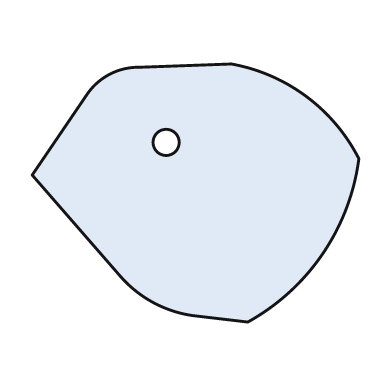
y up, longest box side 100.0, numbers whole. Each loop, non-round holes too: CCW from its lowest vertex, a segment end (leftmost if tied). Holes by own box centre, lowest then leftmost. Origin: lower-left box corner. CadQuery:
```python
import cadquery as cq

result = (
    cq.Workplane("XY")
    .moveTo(66.0, 0.0)
    .threePointArc((89.0, 21.0), (100.0, 50.0))
    .threePointArc((84.0, 69.0), (61.0, 79.0))
    .lineTo(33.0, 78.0)
    .threePointArc((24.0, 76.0), (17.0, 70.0))
    .lineTo(0.0, 45.0)
    .lineTo(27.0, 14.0)
    .threePointArc((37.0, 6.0), (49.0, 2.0))
    .close()
    .moveTo(41.0, 55.0)
    .circle(4.0)
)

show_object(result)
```